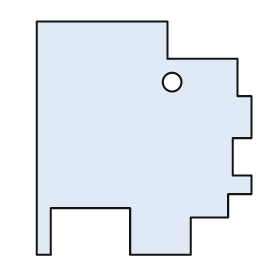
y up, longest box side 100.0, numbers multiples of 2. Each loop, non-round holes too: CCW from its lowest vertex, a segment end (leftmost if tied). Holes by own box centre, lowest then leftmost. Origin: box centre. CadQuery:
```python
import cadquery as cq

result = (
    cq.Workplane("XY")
    .moveTo(-46.0, -50.0)
    .lineTo(-40.0, -50.0)
    .lineTo(-40.0, -30.0)
    .lineTo(-6.0, -30.0)
    .lineTo(-6.0, -50.0)
    .lineTo(20.0, -50.0)
    .lineTo(20.0, -34.0)
    .lineTo(36.0, -34.0)
    .lineTo(36.0, -24.0)
    .lineTo(46.0, -24.0)
    .lineTo(46.0, -16.0)
    .lineTo(38.0, -16.0)
    .lineTo(38.0, 0.0)
    .lineTo(46.0, 0.0)
    .lineTo(46.0, 18.0)
    .lineTo(40.0, 18.0)
    .lineTo(40.0, 34.0)
    .lineTo(10.0, 34.0)
    .lineTo(10.0, 50.0)
    .lineTo(-46.0, 50.0)
    .close()
    .moveTo(12.0, 24.0)
    .circle(4.0)
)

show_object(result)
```